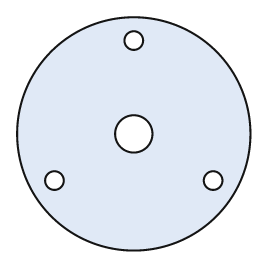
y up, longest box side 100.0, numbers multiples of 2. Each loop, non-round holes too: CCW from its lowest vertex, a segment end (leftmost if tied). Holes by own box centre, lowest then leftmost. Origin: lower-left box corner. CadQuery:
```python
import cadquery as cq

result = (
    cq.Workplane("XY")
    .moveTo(50.0, 50.0)
    .circle(50.0)
    .moveTo(16.0, 30.0)
    .circle(4.0)
    .moveTo(84.0, 30.0)
    .circle(4.0)
    .moveTo(50.0, 50.0)
    .circle(8.0)
    .moveTo(50.0, 90.0)
    .circle(4.0)
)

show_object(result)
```